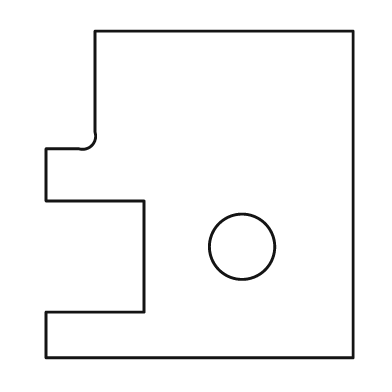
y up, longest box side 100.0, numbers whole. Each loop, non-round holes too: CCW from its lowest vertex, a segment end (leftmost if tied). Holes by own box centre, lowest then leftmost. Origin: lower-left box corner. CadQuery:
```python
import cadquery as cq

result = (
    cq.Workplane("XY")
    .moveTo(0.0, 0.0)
    .lineTo(94.0, 0.0)
    .lineTo(94.0, 100.0)
    .lineTo(15.0, 100.0)
    .lineTo(15.0, 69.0)
    .threePointArc((14.0, 65.0), (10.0, 64.0))
    .lineTo(0.0, 64.0)
    .lineTo(0.0, 48.0)
    .lineTo(30.0, 48.0)
    .lineTo(30.0, 14.0)
    .lineTo(0.0, 14.0)
    .close()
    .moveTo(60.0, 34.0)
    .circle(10.0)
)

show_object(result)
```